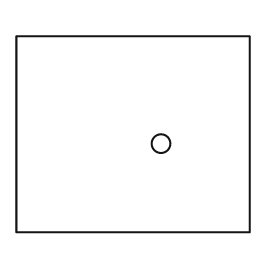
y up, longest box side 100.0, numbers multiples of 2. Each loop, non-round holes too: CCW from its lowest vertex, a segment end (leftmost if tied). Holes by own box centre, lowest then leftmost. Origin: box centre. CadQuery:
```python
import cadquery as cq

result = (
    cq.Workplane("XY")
    .moveTo(-50.0, -42.0)
    .lineTo(50.0, -42.0)
    .lineTo(50.0, 42.0)
    .lineTo(-50.0, 42.0)
    .close()
    .moveTo(12.0, -4.0)
    .circle(4.0)
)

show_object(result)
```